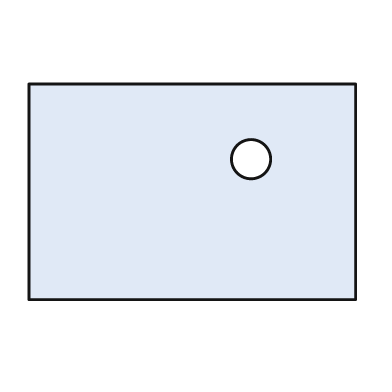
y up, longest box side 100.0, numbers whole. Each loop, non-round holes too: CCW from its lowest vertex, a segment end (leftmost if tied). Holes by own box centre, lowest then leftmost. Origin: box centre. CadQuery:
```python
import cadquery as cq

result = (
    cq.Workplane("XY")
    .moveTo(-50.0, -33.0)
    .lineTo(50.0, -33.0)
    .lineTo(50.0, 33.0)
    .lineTo(-50.0, 33.0)
    .close()
    .moveTo(18.0, 10.0)
    .circle(6.0)
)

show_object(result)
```